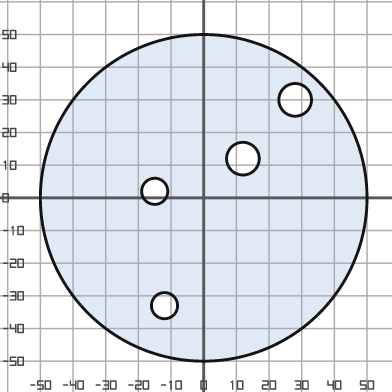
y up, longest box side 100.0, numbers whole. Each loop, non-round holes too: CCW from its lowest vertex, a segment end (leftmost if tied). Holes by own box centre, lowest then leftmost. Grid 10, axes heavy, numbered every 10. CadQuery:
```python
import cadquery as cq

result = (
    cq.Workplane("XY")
    .moveTo(0.0, 0.0)
    .circle(50.0)
    .moveTo(-12.0, -33.0)
    .circle(4.0)
    .moveTo(-15.0, 2.0)
    .circle(4.0)
    .moveTo(12.0, 12.0)
    .circle(5.0)
    .moveTo(28.0, 30.0)
    .circle(5.0)
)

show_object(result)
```